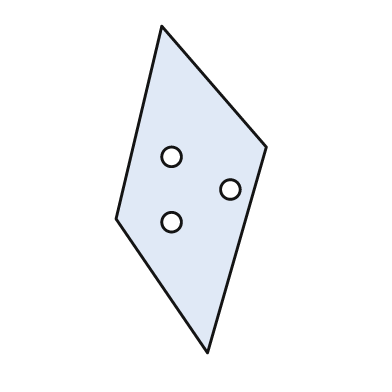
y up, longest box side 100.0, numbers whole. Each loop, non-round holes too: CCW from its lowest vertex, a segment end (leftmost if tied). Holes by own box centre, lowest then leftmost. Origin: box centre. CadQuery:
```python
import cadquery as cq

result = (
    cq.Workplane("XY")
    .moveTo(5.0, -50.0)
    .lineTo(23.0, 13.0)
    .lineTo(-9.0, 50.0)
    .lineTo(-23.0, -9.0)
    .close()
    .moveTo(-6.0, -10.0)
    .circle(3.0)
    .moveTo(12.0, 0.0)
    .circle(3.0)
    .moveTo(-6.0, 10.0)
    .circle(3.0)
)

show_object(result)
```